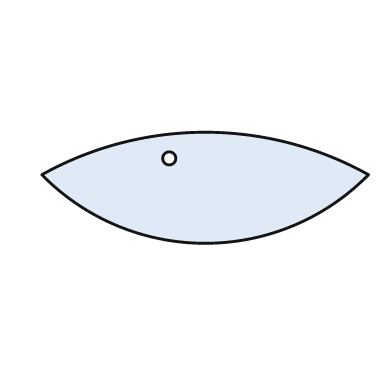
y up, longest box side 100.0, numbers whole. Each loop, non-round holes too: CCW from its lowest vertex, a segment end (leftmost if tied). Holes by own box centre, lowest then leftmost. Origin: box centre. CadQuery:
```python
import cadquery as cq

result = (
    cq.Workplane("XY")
    .moveTo(-50.0, 4.0)
    .threePointArc((0.0, -17.0), (50.0, 4.0))
    .threePointArc((0.0, 17.0), (-50.0, 4.0))
    .close()
    .moveTo(-11.0, 9.0)
    .circle(2.0)
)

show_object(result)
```